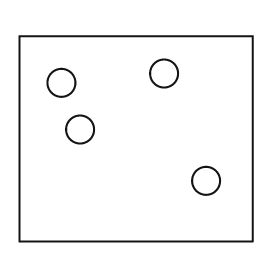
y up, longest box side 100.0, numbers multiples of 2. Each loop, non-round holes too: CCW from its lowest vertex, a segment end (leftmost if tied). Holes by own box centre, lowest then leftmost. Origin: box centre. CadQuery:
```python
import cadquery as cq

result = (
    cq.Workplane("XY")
    .moveTo(-50.0, -44.0)
    .lineTo(50.0, -44.0)
    .lineTo(50.0, 44.0)
    .lineTo(-50.0, 44.0)
    .close()
    .moveTo(30.0, -18.0)
    .circle(6.0)
    .moveTo(-24.0, 4.0)
    .circle(6.0)
    .moveTo(-32.0, 24.0)
    .circle(6.0)
    .moveTo(12.0, 28.0)
    .circle(6.0)
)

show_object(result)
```